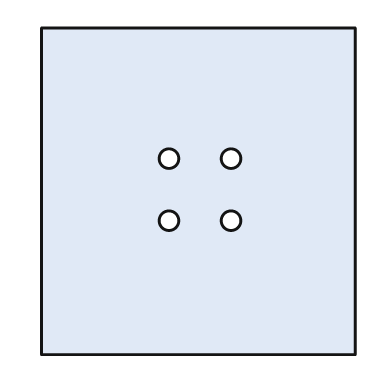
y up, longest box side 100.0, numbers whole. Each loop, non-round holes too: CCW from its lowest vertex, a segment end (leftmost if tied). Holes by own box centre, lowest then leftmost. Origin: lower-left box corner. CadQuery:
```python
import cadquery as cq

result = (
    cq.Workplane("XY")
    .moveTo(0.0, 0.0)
    .lineTo(96.0, 0.0)
    .lineTo(96.0, 100.0)
    .lineTo(0.0, 100.0)
    .close()
    .moveTo(39.0, 41.0)
    .circle(3.0)
    .moveTo(58.0, 41.0)
    .circle(3.0)
    .moveTo(39.0, 60.0)
    .circle(3.0)
    .moveTo(58.0, 60.0)
    .circle(3.0)
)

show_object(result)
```